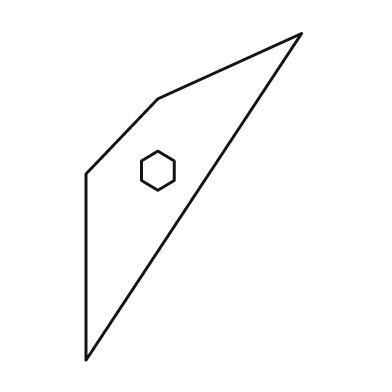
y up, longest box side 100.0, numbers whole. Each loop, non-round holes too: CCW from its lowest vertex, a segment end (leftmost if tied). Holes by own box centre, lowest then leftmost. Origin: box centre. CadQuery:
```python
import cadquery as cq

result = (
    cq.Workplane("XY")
    .moveTo(-33.0, -50.0)
    .lineTo(33.0, 50.0)
    .lineTo(-11.0, 30.0)
    .lineTo(-33.0, 7.0)
    .close()
    .moveTo(-11.0, 2.0)
    .lineTo(-6.0, 5.0)
    .lineTo(-6.0, 11.0)
    .lineTo(-11.0, 14.0)
    .lineTo(-16.0, 11.0)
    .lineTo(-16.0, 5.0)
    .close()
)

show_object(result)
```